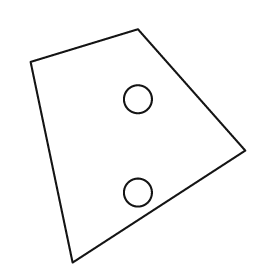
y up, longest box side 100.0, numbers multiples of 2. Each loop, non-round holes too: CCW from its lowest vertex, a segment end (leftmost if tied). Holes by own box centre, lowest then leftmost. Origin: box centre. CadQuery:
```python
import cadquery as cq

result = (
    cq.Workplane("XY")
    .moveTo(-28.0, -50.0)
    .lineTo(46.0, -2.0)
    .lineTo(0.0, 50.0)
    .lineTo(-46.0, 36.0)
    .close()
    .moveTo(0.0, -20.0)
    .circle(6.0)
    .moveTo(0.0, 20.0)
    .circle(6.0)
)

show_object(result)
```